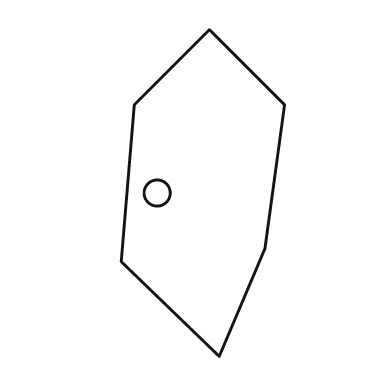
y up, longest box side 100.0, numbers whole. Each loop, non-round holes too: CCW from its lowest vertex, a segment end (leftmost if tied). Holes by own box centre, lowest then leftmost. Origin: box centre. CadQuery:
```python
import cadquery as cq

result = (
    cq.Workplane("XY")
    .moveTo(5.0, -50.0)
    .lineTo(19.0, -17.0)
    .lineTo(25.0, 27.0)
    .lineTo(2.0, 50.0)
    .lineTo(-21.0, 27.0)
    .lineTo(-25.0, -21.0)
    .close()
    .moveTo(-14.0, 0.0)
    .circle(4.0)
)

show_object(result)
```